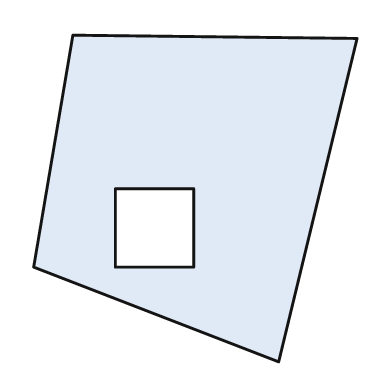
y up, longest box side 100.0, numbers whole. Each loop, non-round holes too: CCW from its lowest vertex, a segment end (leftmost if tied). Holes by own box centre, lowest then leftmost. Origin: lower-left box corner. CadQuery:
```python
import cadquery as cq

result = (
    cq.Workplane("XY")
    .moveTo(75.0, 0.0)
    .lineTo(99.0, 99.0)
    .lineTo(12.0, 100.0)
    .lineTo(0.0, 29.0)
    .close()
    .moveTo(25.0, 29.0)
    .lineTo(49.0, 29.0)
    .lineTo(49.0, 53.0)
    .lineTo(25.0, 53.0)
    .close()
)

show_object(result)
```